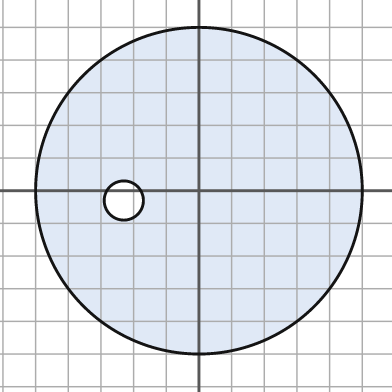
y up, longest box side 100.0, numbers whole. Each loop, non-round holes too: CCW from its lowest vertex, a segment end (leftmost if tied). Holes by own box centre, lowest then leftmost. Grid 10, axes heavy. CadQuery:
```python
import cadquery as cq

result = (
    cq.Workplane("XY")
    .moveTo(0.0, 0.0)
    .circle(50.0)
    .moveTo(-23.0, -3.0)
    .circle(6.0)
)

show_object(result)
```